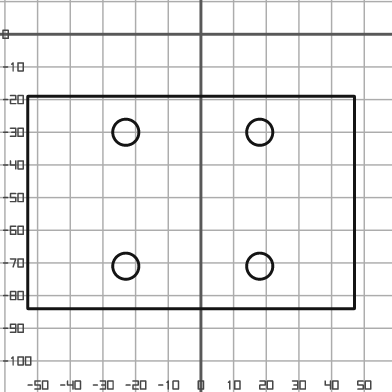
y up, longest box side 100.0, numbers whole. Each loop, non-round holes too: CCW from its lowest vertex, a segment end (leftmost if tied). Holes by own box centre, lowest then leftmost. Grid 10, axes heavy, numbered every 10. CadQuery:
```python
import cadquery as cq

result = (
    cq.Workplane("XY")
    .moveTo(-53.0, -84.0)
    .lineTo(47.0, -84.0)
    .lineTo(47.0, -19.0)
    .lineTo(-53.0, -19.0)
    .close()
    .moveTo(-23.0, -71.0)
    .circle(4.0)
    .moveTo(18.0, -71.0)
    .circle(4.0)
    .moveTo(-23.0, -30.0)
    .circle(4.0)
    .moveTo(18.0, -30.0)
    .circle(4.0)
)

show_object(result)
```